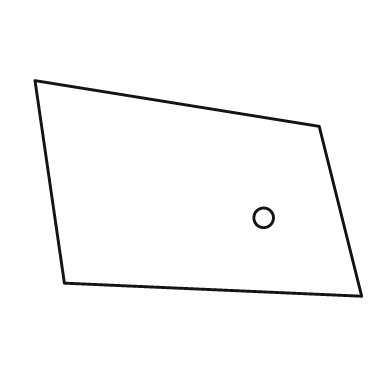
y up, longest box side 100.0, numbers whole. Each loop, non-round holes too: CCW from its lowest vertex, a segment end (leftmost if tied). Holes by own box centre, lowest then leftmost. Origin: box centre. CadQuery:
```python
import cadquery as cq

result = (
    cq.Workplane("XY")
    .moveTo(50.0, -33.0)
    .lineTo(37.0, 19.0)
    .lineTo(-50.0, 33.0)
    .lineTo(-41.0, -29.0)
    .close()
    .moveTo(20.0, -9.0)
    .circle(3.0)
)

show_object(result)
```